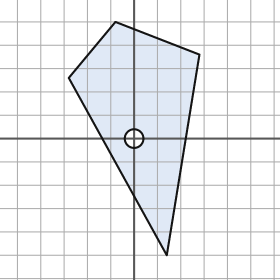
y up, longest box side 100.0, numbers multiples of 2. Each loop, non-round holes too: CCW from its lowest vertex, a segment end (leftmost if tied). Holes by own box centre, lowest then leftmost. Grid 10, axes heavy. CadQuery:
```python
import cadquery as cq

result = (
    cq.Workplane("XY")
    .moveTo(14.0, -50.0)
    .lineTo(28.0, 36.0)
    .lineTo(-8.0, 50.0)
    .lineTo(-28.0, 26.0)
    .close()
    .moveTo(0.0, 0.0)
    .circle(4.0)
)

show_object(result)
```